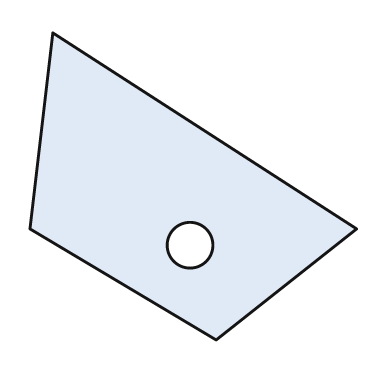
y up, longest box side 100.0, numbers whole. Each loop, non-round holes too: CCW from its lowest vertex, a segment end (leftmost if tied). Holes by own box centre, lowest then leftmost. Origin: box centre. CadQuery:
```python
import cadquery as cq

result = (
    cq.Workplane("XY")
    .moveTo(7.0, -47.0)
    .lineTo(50.0, -13.0)
    .lineTo(-43.0, 47.0)
    .lineTo(-50.0, -13.0)
    .close()
    .moveTo(-1.0, -18.0)
    .circle(7.0)
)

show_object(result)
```